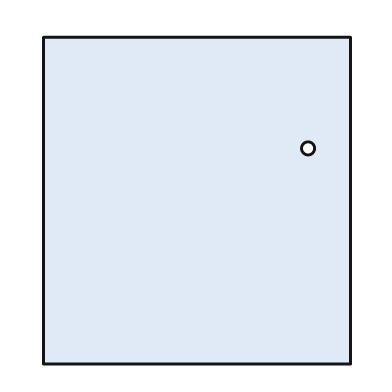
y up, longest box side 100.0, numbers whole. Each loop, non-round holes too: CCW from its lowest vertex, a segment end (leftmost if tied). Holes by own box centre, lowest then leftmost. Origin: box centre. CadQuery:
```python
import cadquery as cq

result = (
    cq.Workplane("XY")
    .moveTo(-47.0, -50.0)
    .lineTo(47.0, -50.0)
    .lineTo(47.0, 50.0)
    .lineTo(-47.0, 50.0)
    .close()
    .moveTo(34.0, 16.0)
    .circle(2.0)
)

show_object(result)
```